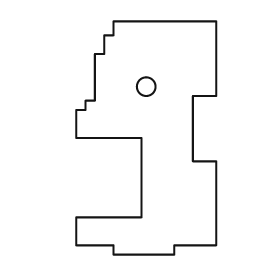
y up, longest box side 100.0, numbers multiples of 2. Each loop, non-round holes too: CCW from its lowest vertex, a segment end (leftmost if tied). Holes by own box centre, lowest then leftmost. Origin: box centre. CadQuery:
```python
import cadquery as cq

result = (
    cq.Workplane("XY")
    .moveTo(-14.0, -50.0)
    .lineTo(12.0, -50.0)
    .lineTo(12.0, -46.0)
    .lineTo(30.0, -46.0)
    .lineTo(30.0, -10.0)
    .lineTo(20.0, -10.0)
    .lineTo(20.0, 18.0)
    .lineTo(30.0, 18.0)
    .lineTo(30.0, 50.0)
    .lineTo(-14.0, 50.0)
    .lineTo(-14.0, 44.0)
    .lineTo(-18.0, 44.0)
    .lineTo(-18.0, 36.0)
    .lineTo(-22.0, 36.0)
    .lineTo(-22.0, 16.0)
    .lineTo(-26.0, 16.0)
    .lineTo(-26.0, 12.0)
    .lineTo(-30.0, 12.0)
    .lineTo(-30.0, 0.0)
    .lineTo(-2.0, 0.0)
    .lineTo(-2.0, -34.0)
    .lineTo(-30.0, -34.0)
    .lineTo(-30.0, -46.0)
    .lineTo(-14.0, -46.0)
    .close()
    .moveTo(0.0, 22.0)
    .circle(4.0)
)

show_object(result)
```